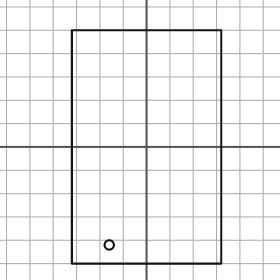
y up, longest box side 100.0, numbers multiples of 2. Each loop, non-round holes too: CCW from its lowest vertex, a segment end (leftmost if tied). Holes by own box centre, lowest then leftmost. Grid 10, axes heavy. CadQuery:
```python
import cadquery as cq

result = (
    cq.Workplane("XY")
    .moveTo(-32.0, -50.0)
    .lineTo(32.0, -50.0)
    .lineTo(32.0, 50.0)
    .lineTo(-32.0, 50.0)
    .close()
    .moveTo(-16.0, -42.0)
    .circle(2.0)
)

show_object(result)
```